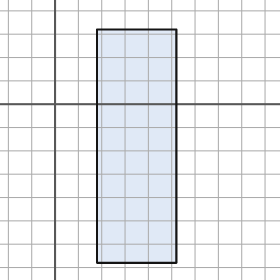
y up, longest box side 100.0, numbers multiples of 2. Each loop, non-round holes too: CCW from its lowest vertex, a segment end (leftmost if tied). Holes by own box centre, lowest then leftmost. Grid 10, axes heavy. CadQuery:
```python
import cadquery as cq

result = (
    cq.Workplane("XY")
    .moveTo(18.0, -68.0)
    .lineTo(52.0, -68.0)
    .lineTo(52.0, 32.0)
    .lineTo(18.0, 32.0)
    .close()
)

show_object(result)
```